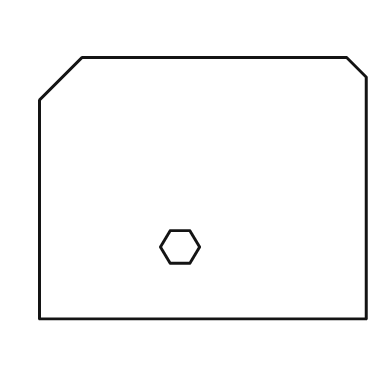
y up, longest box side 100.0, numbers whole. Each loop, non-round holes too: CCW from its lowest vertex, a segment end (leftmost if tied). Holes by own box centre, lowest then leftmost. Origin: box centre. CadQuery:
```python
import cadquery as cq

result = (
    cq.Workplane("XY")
    .moveTo(-50.0, -40.0)
    .lineTo(50.0, -40.0)
    .lineTo(50.0, 34.0)
    .lineTo(44.0, 40.0)
    .lineTo(-37.0, 40.0)
    .lineTo(-50.0, 27.0)
    .close()
    .moveTo(-10.0, -23.0)
    .lineTo(-4.0, -23.0)
    .lineTo(-1.0, -18.0)
    .lineTo(-4.0, -13.0)
    .lineTo(-10.0, -13.0)
    .lineTo(-13.0, -18.0)
    .close()
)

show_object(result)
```